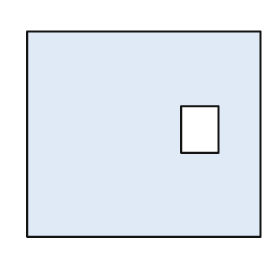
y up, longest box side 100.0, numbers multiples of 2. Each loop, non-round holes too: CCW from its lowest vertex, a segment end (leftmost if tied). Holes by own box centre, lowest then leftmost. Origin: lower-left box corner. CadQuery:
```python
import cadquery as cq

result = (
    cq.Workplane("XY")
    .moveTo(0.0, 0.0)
    .lineTo(100.0, 0.0)
    .lineTo(100.0, 88.0)
    .lineTo(0.0, 88.0)
    .close()
    .moveTo(66.0, 36.0)
    .lineTo(82.0, 36.0)
    .lineTo(82.0, 56.0)
    .lineTo(66.0, 56.0)
    .close()
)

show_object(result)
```